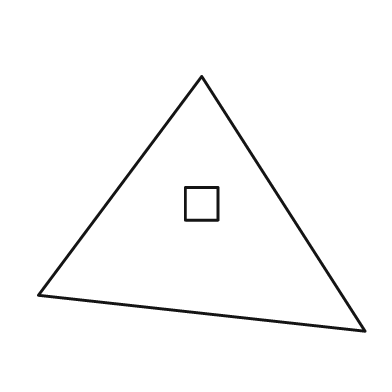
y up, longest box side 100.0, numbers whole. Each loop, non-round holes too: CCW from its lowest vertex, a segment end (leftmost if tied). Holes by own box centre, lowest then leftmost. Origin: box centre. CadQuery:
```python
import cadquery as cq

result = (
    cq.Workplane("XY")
    .moveTo(50.0, -39.0)
    .lineTo(0.0, 39.0)
    .lineTo(-50.0, -28.0)
    .close()
    .moveTo(-5.0, -5.0)
    .lineTo(5.0, -5.0)
    .lineTo(5.0, 5.0)
    .lineTo(-5.0, 5.0)
    .close()
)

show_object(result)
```